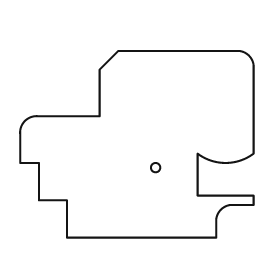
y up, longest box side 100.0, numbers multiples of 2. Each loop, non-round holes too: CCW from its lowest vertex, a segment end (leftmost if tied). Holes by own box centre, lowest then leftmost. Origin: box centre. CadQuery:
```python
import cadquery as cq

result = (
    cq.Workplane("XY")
    .moveTo(-30.0, -40.0)
    .lineTo(34.0, -40.0)
    .lineTo(34.0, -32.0)
    .threePointArc((36.0, -28.0), (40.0, -26.0))
    .lineTo(50.0, -26.0)
    .lineTo(50.0, -22.0)
    .lineTo(26.0, -22.0)
    .lineTo(26.0, -4.0)
    .threePointArc((38.0, -8.0), (50.0, -4.0))
    .lineTo(50.0, 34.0)
    .threePointArc((48.0, 38.0), (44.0, 40.0))
    .lineTo(-8.0, 40.0)
    .lineTo(-16.0, 32.0)
    .lineTo(-16.0, 12.0)
    .lineTo(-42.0, 12.0)
    .threePointArc((-48.0, 10.0), (-50.0, 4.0))
    .lineTo(-50.0, -8.0)
    .lineTo(-42.0, -8.0)
    .lineTo(-42.0, -24.0)
    .lineTo(-30.0, -24.0)
    .close()
    .moveTo(8.0, -10.0)
    .circle(2.0)
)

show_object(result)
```